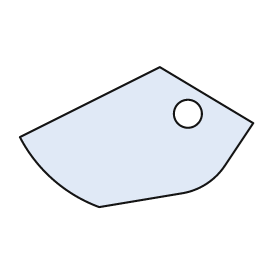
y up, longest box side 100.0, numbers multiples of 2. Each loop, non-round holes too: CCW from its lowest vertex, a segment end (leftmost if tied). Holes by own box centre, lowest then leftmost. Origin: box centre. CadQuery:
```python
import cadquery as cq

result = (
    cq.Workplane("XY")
    .moveTo(-16.0, -30.0)
    .lineTo(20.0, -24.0)
    .threePointArc((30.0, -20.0), (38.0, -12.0))
    .lineTo(50.0, 6.0)
    .lineTo(10.0, 30.0)
    .lineTo(-50.0, 0.0)
    .threePointArc((-36.0, -18.0), (-16.0, -30.0))
    .close()
    .moveTo(22.0, 10.0)
    .circle(6.0)
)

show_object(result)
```